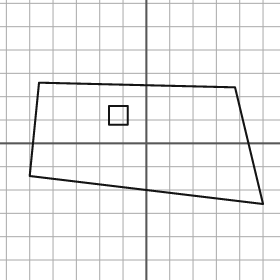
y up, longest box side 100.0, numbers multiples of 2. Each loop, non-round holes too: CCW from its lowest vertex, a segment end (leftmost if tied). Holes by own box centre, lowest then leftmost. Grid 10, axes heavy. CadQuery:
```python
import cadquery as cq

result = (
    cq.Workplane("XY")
    .moveTo(50.0, -26.0)
    .lineTo(38.0, 24.0)
    .lineTo(-46.0, 26.0)
    .lineTo(-50.0, -14.0)
    .close()
    .moveTo(-16.0, 8.0)
    .lineTo(-8.0, 8.0)
    .lineTo(-8.0, 16.0)
    .lineTo(-16.0, 16.0)
    .close()
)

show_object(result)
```